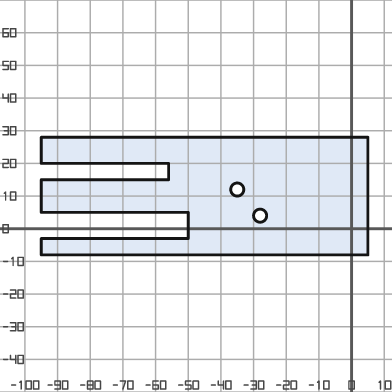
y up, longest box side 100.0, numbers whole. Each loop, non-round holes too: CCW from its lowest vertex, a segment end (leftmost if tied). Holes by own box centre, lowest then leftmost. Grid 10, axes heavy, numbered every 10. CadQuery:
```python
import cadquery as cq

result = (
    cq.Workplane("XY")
    .moveTo(-95.0, -8.0)
    .lineTo(5.0, -8.0)
    .lineTo(5.0, 28.0)
    .lineTo(-95.0, 28.0)
    .lineTo(-95.0, 20.0)
    .lineTo(-56.0, 20.0)
    .lineTo(-56.0, 15.0)
    .lineTo(-95.0, 15.0)
    .lineTo(-95.0, 5.0)
    .lineTo(-50.0, 5.0)
    .lineTo(-50.0, -3.0)
    .lineTo(-95.0, -3.0)
    .close()
    .moveTo(-28.0, 4.0)
    .circle(2.0)
    .moveTo(-35.0, 12.0)
    .circle(2.0)
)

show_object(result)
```